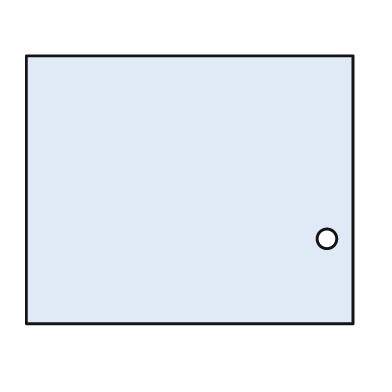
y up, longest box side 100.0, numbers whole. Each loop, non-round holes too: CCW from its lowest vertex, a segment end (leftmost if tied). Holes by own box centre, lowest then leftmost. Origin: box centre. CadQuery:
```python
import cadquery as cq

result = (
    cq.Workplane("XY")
    .moveTo(-50.0, -41.0)
    .lineTo(50.0, -41.0)
    .lineTo(50.0, 41.0)
    .lineTo(-50.0, 41.0)
    .close()
    .moveTo(42.0, -15.0)
    .circle(3.0)
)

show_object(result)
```